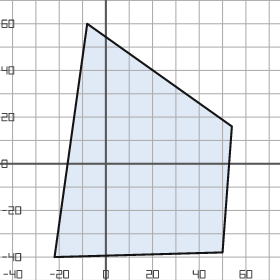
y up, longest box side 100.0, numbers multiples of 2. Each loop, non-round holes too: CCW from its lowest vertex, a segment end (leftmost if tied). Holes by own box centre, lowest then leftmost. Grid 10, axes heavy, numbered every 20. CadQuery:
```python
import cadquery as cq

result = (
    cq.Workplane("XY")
    .moveTo(-22.0, -40.0)
    .lineTo(50.0, -38.0)
    .lineTo(54.0, 16.0)
    .lineTo(-8.0, 60.0)
    .close()
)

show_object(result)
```